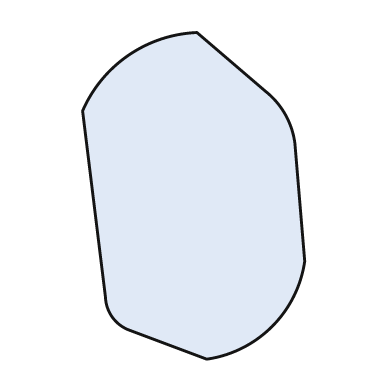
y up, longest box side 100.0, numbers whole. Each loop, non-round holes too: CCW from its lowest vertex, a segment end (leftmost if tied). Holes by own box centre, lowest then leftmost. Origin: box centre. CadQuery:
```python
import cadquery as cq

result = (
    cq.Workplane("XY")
    .moveTo(4.0, -50.0)
    .threePointArc((24.0, -40.0), (34.0, -20.0))
    .lineTo(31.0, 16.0)
    .threePointArc((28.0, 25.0), (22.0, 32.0))
    .lineTo(1.0, 50.0)
    .threePointArc((-20.0, 43.0), (-34.0, 26.0))
    .lineTo(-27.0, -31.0)
    .threePointArc((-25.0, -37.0), (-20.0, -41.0))
    .close()
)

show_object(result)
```